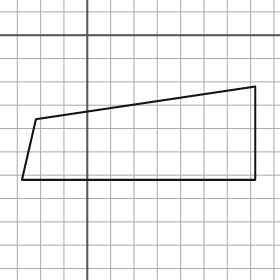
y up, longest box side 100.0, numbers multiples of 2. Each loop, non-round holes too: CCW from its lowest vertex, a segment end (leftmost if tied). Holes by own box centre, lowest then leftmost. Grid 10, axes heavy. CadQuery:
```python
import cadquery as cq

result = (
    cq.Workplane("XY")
    .moveTo(-28.0, -62.0)
    .lineTo(72.0, -62.0)
    .lineTo(72.0, -22.0)
    .lineTo(-22.0, -36.0)
    .close()
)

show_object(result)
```